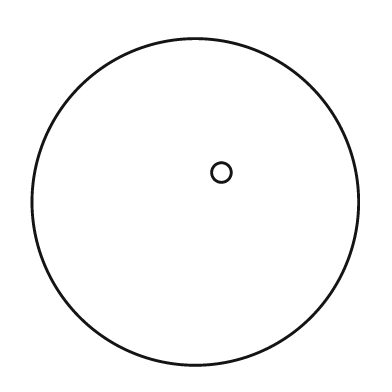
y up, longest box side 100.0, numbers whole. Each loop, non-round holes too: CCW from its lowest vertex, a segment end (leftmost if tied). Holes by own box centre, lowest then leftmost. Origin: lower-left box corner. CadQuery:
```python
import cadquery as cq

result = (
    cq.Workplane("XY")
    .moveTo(50.0, 50.0)
    .circle(50.0)
    .moveTo(58.0, 59.0)
    .circle(3.0)
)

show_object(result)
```